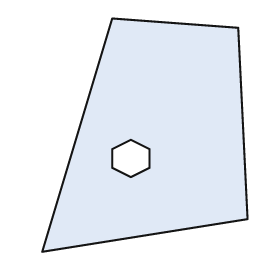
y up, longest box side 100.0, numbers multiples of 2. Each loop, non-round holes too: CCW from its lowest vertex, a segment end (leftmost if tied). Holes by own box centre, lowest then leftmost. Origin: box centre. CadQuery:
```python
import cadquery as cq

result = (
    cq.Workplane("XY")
    .moveTo(-44.0, -50.0)
    .lineTo(44.0, -36.0)
    .lineTo(40.0, 46.0)
    .lineTo(-14.0, 50.0)
    .close()
    .moveTo(-6.0, -18.0)
    .lineTo(2.0, -14.0)
    .lineTo(2.0, -6.0)
    .lineTo(-6.0, -2.0)
    .lineTo(-14.0, -6.0)
    .lineTo(-14.0, -14.0)
    .close()
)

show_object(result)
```